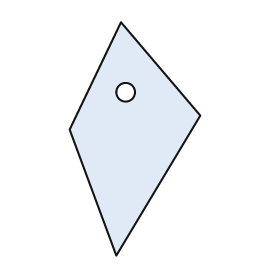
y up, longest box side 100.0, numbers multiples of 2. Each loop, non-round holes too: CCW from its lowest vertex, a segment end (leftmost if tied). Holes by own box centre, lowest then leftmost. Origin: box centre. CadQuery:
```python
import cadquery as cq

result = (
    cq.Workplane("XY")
    .moveTo(-8.0, -50.0)
    .lineTo(28.0, 10.0)
    .lineTo(-6.0, 50.0)
    .lineTo(-28.0, 4.0)
    .close()
    .moveTo(-4.0, 20.0)
    .circle(4.0)
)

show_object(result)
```